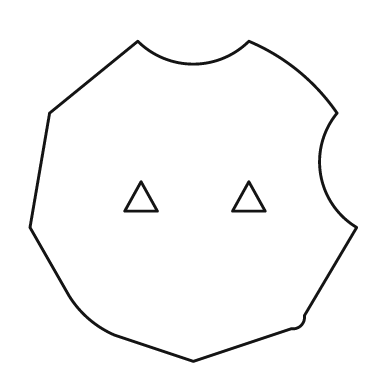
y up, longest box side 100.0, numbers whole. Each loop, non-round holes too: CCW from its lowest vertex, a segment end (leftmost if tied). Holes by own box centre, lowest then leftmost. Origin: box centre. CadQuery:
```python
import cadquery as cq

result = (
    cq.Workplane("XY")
    .moveTo(0.0, -49.0)
    .lineTo(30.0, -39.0)
    .threePointArc((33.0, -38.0), (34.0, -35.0))
    .lineTo(50.0, -8.0)
    .threePointArc((39.0, 8.0), (44.0, 27.0))
    .threePointArc((32.0, 40.0), (17.0, 49.0))
    .threePointArc((0.0, 42.0), (-17.0, 49.0))
    .lineTo(-44.0, 27.0)
    .lineTo(-50.0, -8.0)
    .lineTo(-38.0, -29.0)
    .threePointArc((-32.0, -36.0), (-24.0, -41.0))
    .close()
    .moveTo(-21.0, -3.0)
    .lineTo(-11.0, -3.0)
    .lineTo(-16.0, 6.0)
    .close()
    .moveTo(12.0, -3.0)
    .lineTo(22.0, -3.0)
    .lineTo(17.0, 6.0)
    .close()
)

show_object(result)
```